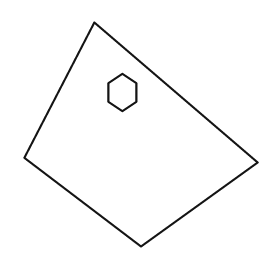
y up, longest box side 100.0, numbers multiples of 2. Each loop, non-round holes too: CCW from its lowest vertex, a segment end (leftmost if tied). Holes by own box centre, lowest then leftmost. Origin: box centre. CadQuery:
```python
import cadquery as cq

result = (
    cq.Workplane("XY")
    .moveTo(0.0, -48.0)
    .lineTo(50.0, -12.0)
    .lineTo(-20.0, 48.0)
    .lineTo(-50.0, -10.0)
    .close()
    .moveTo(-8.0, 10.0)
    .lineTo(-2.0, 14.0)
    .lineTo(-2.0, 22.0)
    .lineTo(-8.0, 26.0)
    .lineTo(-14.0, 22.0)
    .lineTo(-14.0, 14.0)
    .close()
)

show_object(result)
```